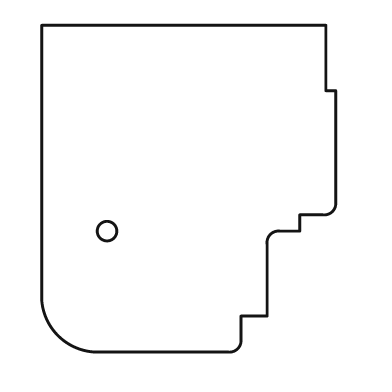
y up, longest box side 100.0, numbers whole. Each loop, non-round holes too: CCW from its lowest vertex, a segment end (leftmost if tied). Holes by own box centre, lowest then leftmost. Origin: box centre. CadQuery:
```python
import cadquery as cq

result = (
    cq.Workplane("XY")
    .moveTo(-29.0, -50.0)
    .lineTo(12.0, -50.0)
    .threePointArc((15.0, -49.0), (16.0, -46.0))
    .lineTo(16.0, -39.0)
    .lineTo(24.0, -39.0)
    .lineTo(24.0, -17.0)
    .threePointArc((25.0, -14.0), (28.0, -13.0))
    .lineTo(34.0, -13.0)
    .lineTo(34.0, -8.0)
    .lineTo(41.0, -8.0)
    .threePointArc((44.0, -7.0), (45.0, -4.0))
    .lineTo(45.0, 30.0)
    .lineTo(42.0, 30.0)
    .lineTo(42.0, 50.0)
    .lineTo(-45.0, 50.0)
    .lineTo(-45.0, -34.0)
    .threePointArc((-40.0, -45.0), (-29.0, -50.0))
    .close()
    .moveTo(-25.0, -13.0)
    .circle(3.0)
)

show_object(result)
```